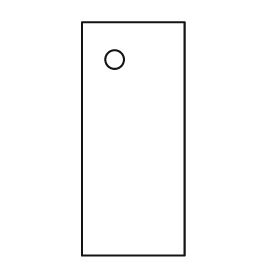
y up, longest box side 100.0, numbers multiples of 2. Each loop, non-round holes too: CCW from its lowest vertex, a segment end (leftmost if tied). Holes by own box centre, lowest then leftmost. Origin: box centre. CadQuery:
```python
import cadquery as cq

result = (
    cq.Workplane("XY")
    .moveTo(-22.0, -50.0)
    .lineTo(22.0, -50.0)
    .lineTo(22.0, 50.0)
    .lineTo(-22.0, 50.0)
    .close()
    .moveTo(-8.0, 34.0)
    .circle(4.0)
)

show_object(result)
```